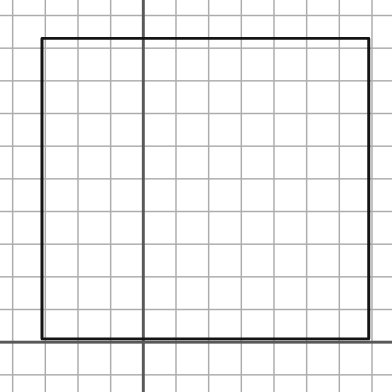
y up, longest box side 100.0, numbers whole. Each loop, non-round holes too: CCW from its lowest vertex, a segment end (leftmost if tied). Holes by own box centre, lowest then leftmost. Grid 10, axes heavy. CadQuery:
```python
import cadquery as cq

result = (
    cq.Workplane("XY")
    .moveTo(-31.0, 1.0)
    .lineTo(69.0, 1.0)
    .lineTo(69.0, 93.0)
    .lineTo(-31.0, 93.0)
    .close()
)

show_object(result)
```